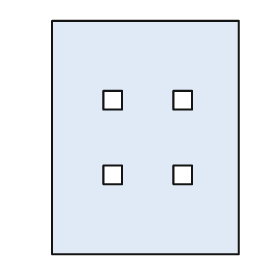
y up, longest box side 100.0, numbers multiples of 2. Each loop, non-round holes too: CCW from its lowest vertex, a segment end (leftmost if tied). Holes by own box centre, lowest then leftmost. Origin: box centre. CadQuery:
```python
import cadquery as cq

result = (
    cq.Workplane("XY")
    .moveTo(-40.0, -50.0)
    .lineTo(40.0, -50.0)
    .lineTo(40.0, 50.0)
    .lineTo(-40.0, 50.0)
    .close()
    .moveTo(-18.0, -20.0)
    .lineTo(-10.0, -20.0)
    .lineTo(-10.0, -12.0)
    .lineTo(-18.0, -12.0)
    .close()
    .moveTo(12.0, -20.0)
    .lineTo(20.0, -20.0)
    .lineTo(20.0, -12.0)
    .lineTo(12.0, -12.0)
    .close()
    .moveTo(-18.0, 12.0)
    .lineTo(-10.0, 12.0)
    .lineTo(-10.0, 20.0)
    .lineTo(-18.0, 20.0)
    .close()
    .moveTo(12.0, 12.0)
    .lineTo(20.0, 12.0)
    .lineTo(20.0, 20.0)
    .lineTo(12.0, 20.0)
    .close()
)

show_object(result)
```